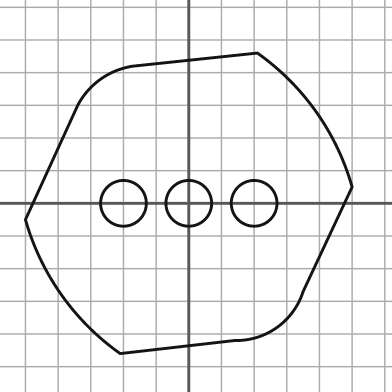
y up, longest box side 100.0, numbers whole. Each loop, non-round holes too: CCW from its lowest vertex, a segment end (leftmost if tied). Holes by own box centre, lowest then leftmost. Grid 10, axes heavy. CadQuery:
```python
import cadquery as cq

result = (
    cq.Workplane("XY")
    .moveTo(-21.0, -46.0)
    .lineTo(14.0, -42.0)
    .threePointArc((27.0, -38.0), (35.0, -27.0))
    .lineTo(50.0, 5.0)
    .threePointArc((39.0, 28.0), (21.0, 46.0))
    .lineTo(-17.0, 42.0)
    .threePointArc((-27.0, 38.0), (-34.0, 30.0))
    .lineTo(-50.0, -5.0)
    .threePointArc((-39.0, -28.0), (-21.0, -46.0))
    .close()
    .moveTo(-20.0, 0.0)
    .circle(7.0)
    .moveTo(0.0, 0.0)
    .circle(7.0)
    .moveTo(20.0, 0.0)
    .circle(7.0)
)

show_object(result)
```